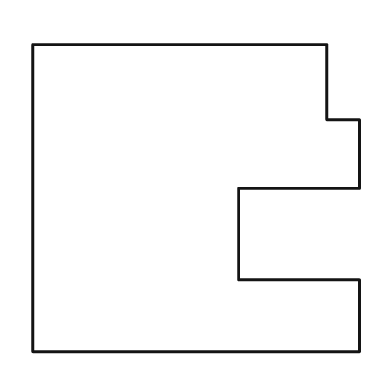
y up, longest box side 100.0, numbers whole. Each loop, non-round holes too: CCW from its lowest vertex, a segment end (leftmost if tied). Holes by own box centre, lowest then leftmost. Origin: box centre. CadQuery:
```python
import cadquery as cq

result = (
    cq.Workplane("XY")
    .moveTo(-50.0, -47.0)
    .lineTo(50.0, -47.0)
    .lineTo(50.0, -25.0)
    .lineTo(13.0, -25.0)
    .lineTo(13.0, 3.0)
    .lineTo(50.0, 3.0)
    .lineTo(50.0, 24.0)
    .lineTo(40.0, 24.0)
    .lineTo(40.0, 47.0)
    .lineTo(-50.0, 47.0)
    .close()
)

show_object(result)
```